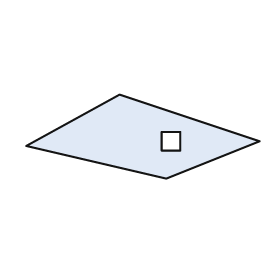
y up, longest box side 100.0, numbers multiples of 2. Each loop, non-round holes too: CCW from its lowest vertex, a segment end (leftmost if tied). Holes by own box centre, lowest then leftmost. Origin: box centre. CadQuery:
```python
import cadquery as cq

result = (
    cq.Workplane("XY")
    .moveTo(10.0, -18.0)
    .lineTo(50.0, -2.0)
    .lineTo(-10.0, 18.0)
    .lineTo(-50.0, -4.0)
    .close()
    .moveTo(8.0, -6.0)
    .lineTo(16.0, -6.0)
    .lineTo(16.0, 2.0)
    .lineTo(8.0, 2.0)
    .close()
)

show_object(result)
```